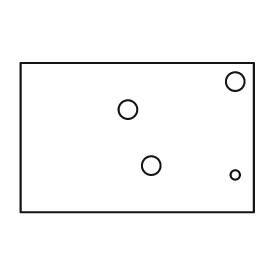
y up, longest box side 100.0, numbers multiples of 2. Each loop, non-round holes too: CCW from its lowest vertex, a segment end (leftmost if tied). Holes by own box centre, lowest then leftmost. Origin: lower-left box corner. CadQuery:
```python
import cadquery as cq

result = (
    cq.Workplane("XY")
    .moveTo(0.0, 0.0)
    .lineTo(100.0, 0.0)
    .lineTo(100.0, 64.0)
    .lineTo(0.0, 64.0)
    .close()
    .moveTo(92.0, 16.0)
    .circle(2.0)
    .moveTo(56.0, 20.0)
    .circle(4.0)
    .moveTo(46.0, 44.0)
    .circle(4.0)
    .moveTo(92.0, 56.0)
    .circle(4.0)
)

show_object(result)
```